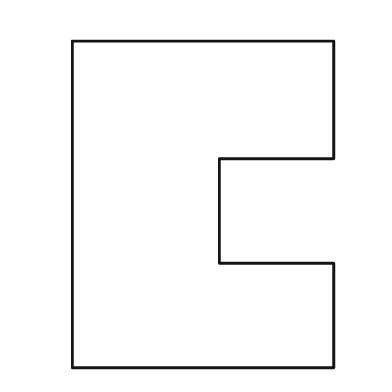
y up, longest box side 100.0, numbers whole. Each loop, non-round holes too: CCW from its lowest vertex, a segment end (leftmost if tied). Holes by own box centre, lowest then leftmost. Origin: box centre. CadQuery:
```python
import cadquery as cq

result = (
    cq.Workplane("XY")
    .moveTo(-40.0, -50.0)
    .lineTo(40.0, -50.0)
    .lineTo(40.0, -18.0)
    .lineTo(5.0, -18.0)
    .lineTo(5.0, 14.0)
    .lineTo(40.0, 14.0)
    .lineTo(40.0, 50.0)
    .lineTo(-40.0, 50.0)
    .close()
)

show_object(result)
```